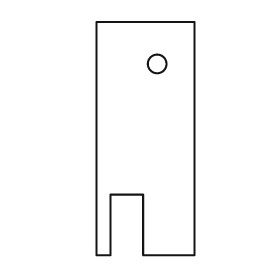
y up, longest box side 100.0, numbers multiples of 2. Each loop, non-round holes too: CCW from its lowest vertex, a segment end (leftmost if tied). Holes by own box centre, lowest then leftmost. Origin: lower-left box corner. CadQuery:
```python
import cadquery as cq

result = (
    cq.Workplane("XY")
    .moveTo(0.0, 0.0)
    .lineTo(6.0, 0.0)
    .lineTo(6.0, 26.0)
    .lineTo(20.0, 26.0)
    .lineTo(20.0, 0.0)
    .lineTo(42.0, 0.0)
    .lineTo(42.0, 100.0)
    .lineTo(0.0, 100.0)
    .close()
    .moveTo(26.0, 82.0)
    .circle(4.0)
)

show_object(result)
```